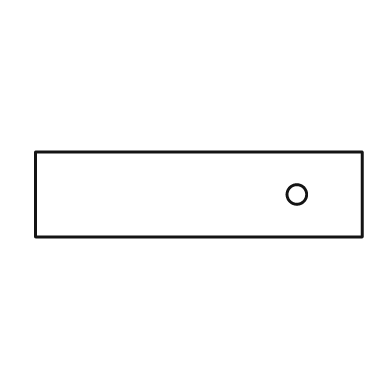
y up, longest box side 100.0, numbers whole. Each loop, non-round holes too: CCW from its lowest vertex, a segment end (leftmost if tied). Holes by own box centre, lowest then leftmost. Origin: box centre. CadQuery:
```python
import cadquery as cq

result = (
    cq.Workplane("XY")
    .moveTo(-50.0, -13.0)
    .lineTo(50.0, -13.0)
    .lineTo(50.0, 13.0)
    .lineTo(-50.0, 13.0)
    .close()
    .moveTo(30.0, 0.0)
    .circle(3.0)
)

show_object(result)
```